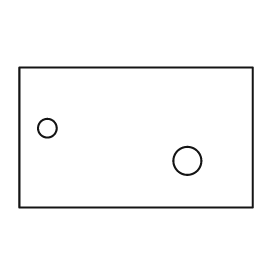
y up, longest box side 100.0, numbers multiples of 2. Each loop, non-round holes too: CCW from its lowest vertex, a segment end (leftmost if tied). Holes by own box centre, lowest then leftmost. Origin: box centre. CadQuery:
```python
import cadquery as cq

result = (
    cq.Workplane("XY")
    .moveTo(-50.0, -30.0)
    .lineTo(50.0, -30.0)
    .lineTo(50.0, 30.0)
    .lineTo(-50.0, 30.0)
    .close()
    .moveTo(22.0, -10.0)
    .circle(6.0)
    .moveTo(-38.0, 4.0)
    .circle(4.0)
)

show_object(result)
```